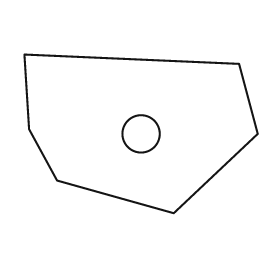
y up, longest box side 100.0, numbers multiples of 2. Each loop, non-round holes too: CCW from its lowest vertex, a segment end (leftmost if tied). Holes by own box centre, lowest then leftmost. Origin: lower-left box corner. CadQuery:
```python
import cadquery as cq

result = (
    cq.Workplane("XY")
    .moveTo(64.0, 0.0)
    .lineTo(100.0, 34.0)
    .lineTo(92.0, 64.0)
    .lineTo(0.0, 68.0)
    .lineTo(2.0, 36.0)
    .lineTo(14.0, 14.0)
    .close()
    .moveTo(50.0, 34.0)
    .circle(8.0)
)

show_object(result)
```